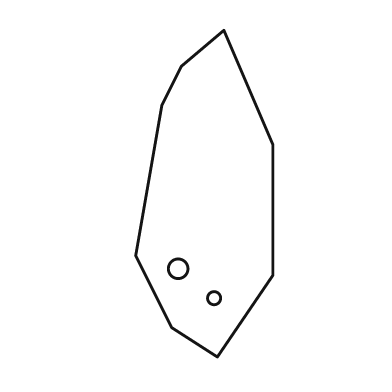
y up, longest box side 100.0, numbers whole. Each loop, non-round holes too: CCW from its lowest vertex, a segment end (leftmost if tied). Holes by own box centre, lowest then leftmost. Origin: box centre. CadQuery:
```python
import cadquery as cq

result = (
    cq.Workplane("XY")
    .moveTo(4.0, -50.0)
    .lineTo(21.0, -25.0)
    .lineTo(21.0, 15.0)
    .lineTo(6.0, 50.0)
    .lineTo(-7.0, 39.0)
    .lineTo(-13.0, 27.0)
    .lineTo(-21.0, -19.0)
    .lineTo(-10.0, -41.0)
    .close()
    .moveTo(3.0, -32.0)
    .circle(2.0)
    .moveTo(-8.0, -23.0)
    .circle(3.0)
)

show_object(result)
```